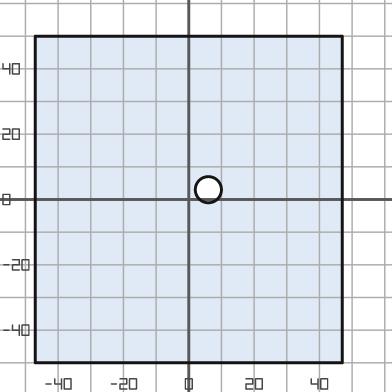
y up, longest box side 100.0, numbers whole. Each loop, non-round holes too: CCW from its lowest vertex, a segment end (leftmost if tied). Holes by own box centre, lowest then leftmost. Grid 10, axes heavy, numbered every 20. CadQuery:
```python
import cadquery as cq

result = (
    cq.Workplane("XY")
    .moveTo(-47.0, -50.0)
    .lineTo(47.0, -50.0)
    .lineTo(47.0, 50.0)
    .lineTo(-47.0, 50.0)
    .close()
    .moveTo(6.0, 3.0)
    .circle(4.0)
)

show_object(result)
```